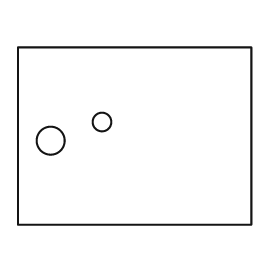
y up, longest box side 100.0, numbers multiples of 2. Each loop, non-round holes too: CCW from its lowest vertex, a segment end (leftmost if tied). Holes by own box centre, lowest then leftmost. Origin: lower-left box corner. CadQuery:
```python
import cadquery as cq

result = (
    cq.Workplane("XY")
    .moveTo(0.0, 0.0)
    .lineTo(100.0, 0.0)
    .lineTo(100.0, 76.0)
    .lineTo(0.0, 76.0)
    .close()
    .moveTo(14.0, 36.0)
    .circle(6.0)
    .moveTo(36.0, 44.0)
    .circle(4.0)
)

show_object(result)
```